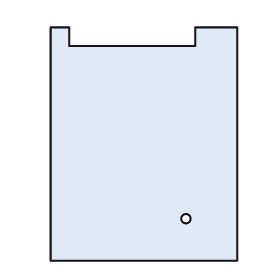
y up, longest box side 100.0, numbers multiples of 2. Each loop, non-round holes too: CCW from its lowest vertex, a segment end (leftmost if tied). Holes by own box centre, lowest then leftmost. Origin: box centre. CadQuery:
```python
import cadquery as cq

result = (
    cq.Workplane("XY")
    .moveTo(-40.0, -50.0)
    .lineTo(40.0, -50.0)
    .lineTo(40.0, 50.0)
    .lineTo(22.0, 50.0)
    .lineTo(22.0, 42.0)
    .lineTo(-32.0, 42.0)
    .lineTo(-32.0, 50.0)
    .lineTo(-40.0, 50.0)
    .close()
    .moveTo(18.0, -32.0)
    .circle(2.0)
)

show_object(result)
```